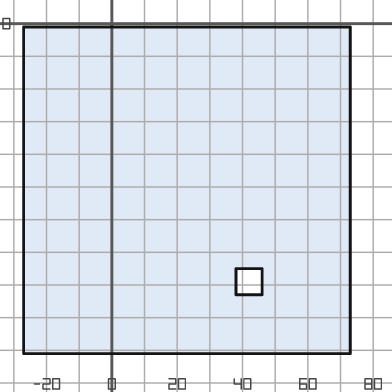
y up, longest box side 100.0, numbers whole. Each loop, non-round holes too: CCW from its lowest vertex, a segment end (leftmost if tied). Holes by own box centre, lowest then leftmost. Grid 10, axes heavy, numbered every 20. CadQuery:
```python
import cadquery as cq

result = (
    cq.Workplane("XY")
    .moveTo(-27.0, -101.0)
    .lineTo(73.0, -101.0)
    .lineTo(73.0, -1.0)
    .lineTo(-27.0, -1.0)
    .close()
    .moveTo(38.0, -83.0)
    .lineTo(46.0, -83.0)
    .lineTo(46.0, -75.0)
    .lineTo(38.0, -75.0)
    .close()
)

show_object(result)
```